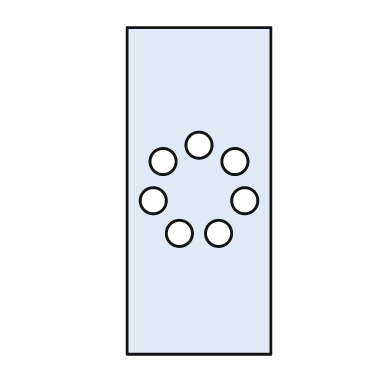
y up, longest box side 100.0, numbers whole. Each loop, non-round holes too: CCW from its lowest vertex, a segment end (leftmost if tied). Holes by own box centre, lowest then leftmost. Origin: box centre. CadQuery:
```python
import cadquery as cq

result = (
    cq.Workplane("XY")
    .moveTo(-22.0, -50.0)
    .lineTo(22.0, -50.0)
    .lineTo(22.0, 50.0)
    .lineTo(-22.0, 50.0)
    .close()
    .moveTo(-6.0, -13.0)
    .circle(4.0)
    .moveTo(6.0, -13.0)
    .circle(4.0)
    .moveTo(-14.0, -3.0)
    .circle(4.0)
    .moveTo(14.0, -3.0)
    .circle(4.0)
    .moveTo(-11.0, 9.0)
    .circle(4.0)
    .moveTo(11.0, 9.0)
    .circle(4.0)
    .moveTo(0.0, 14.0)
    .circle(4.0)
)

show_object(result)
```